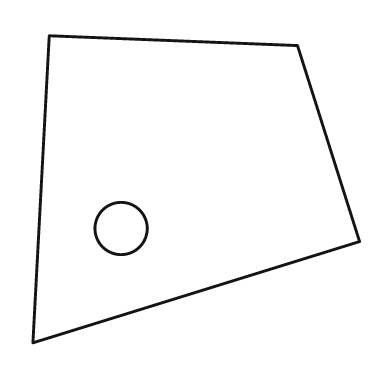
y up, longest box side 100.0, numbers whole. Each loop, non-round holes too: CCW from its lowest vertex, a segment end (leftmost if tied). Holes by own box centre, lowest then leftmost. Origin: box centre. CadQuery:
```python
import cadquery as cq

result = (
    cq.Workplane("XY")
    .moveTo(-50.0, -47.0)
    .lineTo(50.0, -16.0)
    .lineTo(31.0, 44.0)
    .lineTo(-45.0, 47.0)
    .close()
    .moveTo(-23.0, -12.0)
    .circle(8.0)
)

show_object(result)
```